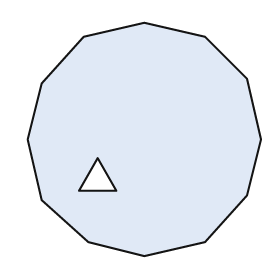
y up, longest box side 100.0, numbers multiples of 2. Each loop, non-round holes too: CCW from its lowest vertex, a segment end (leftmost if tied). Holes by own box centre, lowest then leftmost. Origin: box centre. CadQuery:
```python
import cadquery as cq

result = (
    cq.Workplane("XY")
    .moveTo(0.0, -50.0)
    .lineTo(26.0, -44.0)
    .lineTo(44.0, -24.0)
    .lineTo(50.0, 0.0)
    .lineTo(44.0, 26.0)
    .lineTo(26.0, 44.0)
    .lineTo(0.0, 50.0)
    .lineTo(-26.0, 44.0)
    .lineTo(-44.0, 24.0)
    .lineTo(-50.0, 0.0)
    .lineTo(-44.0, -26.0)
    .lineTo(-24.0, -44.0)
    .close()
    .moveTo(-28.0, -22.0)
    .lineTo(-12.0, -22.0)
    .lineTo(-20.0, -8.0)
    .close()
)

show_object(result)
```